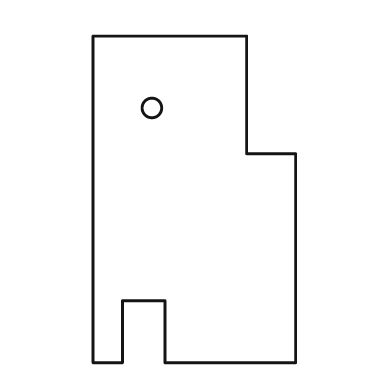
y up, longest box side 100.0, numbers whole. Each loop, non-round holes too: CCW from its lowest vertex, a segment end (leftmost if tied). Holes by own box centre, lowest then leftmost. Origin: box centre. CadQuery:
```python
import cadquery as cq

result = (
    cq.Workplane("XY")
    .moveTo(-31.0, -50.0)
    .lineTo(-22.0, -50.0)
    .lineTo(-22.0, -31.0)
    .lineTo(-9.0, -31.0)
    .lineTo(-9.0, -50.0)
    .lineTo(31.0, -50.0)
    .lineTo(31.0, 14.0)
    .lineTo(16.0, 14.0)
    .lineTo(16.0, 50.0)
    .lineTo(-31.0, 50.0)
    .close()
    .moveTo(-13.0, 28.0)
    .circle(3.0)
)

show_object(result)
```